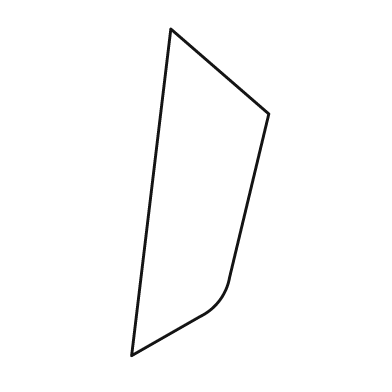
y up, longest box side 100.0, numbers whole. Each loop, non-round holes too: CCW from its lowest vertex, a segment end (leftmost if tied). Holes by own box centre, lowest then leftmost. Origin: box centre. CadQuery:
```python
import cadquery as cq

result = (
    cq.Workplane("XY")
    .moveTo(-21.0, -50.0)
    .lineTo(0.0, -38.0)
    .threePointArc((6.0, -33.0), (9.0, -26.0))
    .lineTo(21.0, 24.0)
    .lineTo(-9.0, 50.0)
    .close()
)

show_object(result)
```